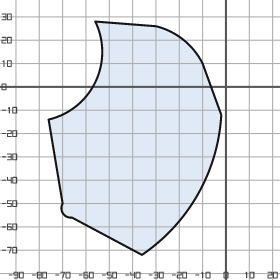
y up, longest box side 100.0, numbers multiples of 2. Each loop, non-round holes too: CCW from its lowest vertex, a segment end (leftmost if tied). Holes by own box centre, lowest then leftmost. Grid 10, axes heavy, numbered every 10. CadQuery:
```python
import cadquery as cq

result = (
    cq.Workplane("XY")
    .moveTo(-36.0, -72.0)
    .threePointArc((-12.0, -46.0), (-2.0, -12.0))
    .lineTo(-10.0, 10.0)
    .threePointArc((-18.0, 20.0), (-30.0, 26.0))
    .lineTo(-56.0, 28.0)
    .threePointArc((-56.0, 2.0), (-76.0, -14.0))
    .lineTo(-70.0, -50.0)
    .threePointArc((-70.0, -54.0), (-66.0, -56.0))
    .close()
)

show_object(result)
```